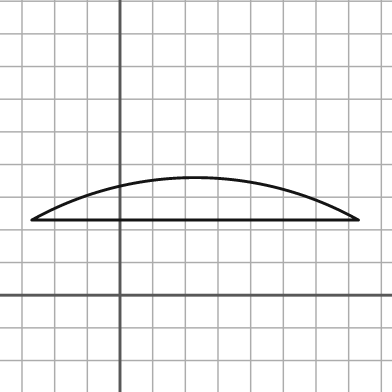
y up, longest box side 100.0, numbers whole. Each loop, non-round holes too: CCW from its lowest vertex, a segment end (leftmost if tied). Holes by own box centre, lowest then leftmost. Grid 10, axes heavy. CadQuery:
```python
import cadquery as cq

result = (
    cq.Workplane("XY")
    .moveTo(-27.0, 23.0)
    .lineTo(73.0, 23.0)
    .threePointArc((23.0, 36.0), (-27.0, 23.0))
    .close()
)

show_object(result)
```